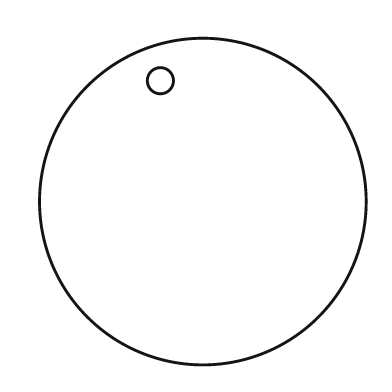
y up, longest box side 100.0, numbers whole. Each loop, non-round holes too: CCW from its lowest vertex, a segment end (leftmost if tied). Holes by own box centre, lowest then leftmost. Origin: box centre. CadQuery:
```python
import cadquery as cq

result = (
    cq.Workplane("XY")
    .moveTo(0.0, 0.0)
    .circle(50.0)
    .moveTo(-13.0, 37.0)
    .circle(4.0)
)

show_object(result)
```